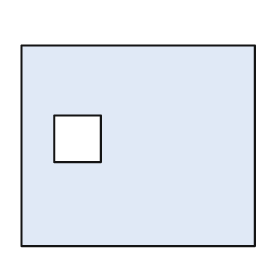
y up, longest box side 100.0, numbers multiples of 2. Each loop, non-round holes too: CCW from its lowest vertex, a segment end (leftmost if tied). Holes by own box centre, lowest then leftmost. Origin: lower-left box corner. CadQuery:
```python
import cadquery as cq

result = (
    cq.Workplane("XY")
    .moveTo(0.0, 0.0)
    .lineTo(100.0, 0.0)
    .lineTo(100.0, 86.0)
    .lineTo(0.0, 86.0)
    .close()
    .moveTo(14.0, 36.0)
    .lineTo(34.0, 36.0)
    .lineTo(34.0, 56.0)
    .lineTo(14.0, 56.0)
    .close()
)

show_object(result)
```